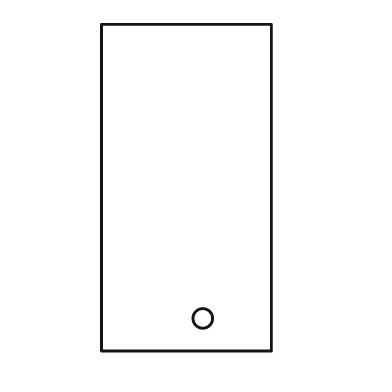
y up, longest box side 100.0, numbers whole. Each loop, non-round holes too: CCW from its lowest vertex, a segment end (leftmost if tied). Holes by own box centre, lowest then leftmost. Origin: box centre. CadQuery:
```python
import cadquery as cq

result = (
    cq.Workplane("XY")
    .moveTo(-26.0, -50.0)
    .lineTo(26.0, -50.0)
    .lineTo(26.0, 50.0)
    .lineTo(-26.0, 50.0)
    .close()
    .moveTo(5.0, -40.0)
    .circle(3.0)
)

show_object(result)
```